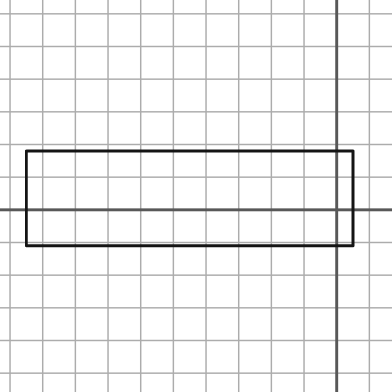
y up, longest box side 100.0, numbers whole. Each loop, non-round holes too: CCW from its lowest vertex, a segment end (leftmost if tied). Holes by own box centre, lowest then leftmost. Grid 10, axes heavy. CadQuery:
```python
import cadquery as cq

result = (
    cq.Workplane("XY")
    .moveTo(-95.0, -11.0)
    .lineTo(5.0, -11.0)
    .lineTo(5.0, 18.0)
    .lineTo(-95.0, 18.0)
    .close()
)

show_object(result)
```